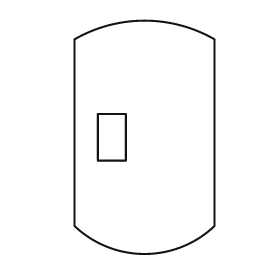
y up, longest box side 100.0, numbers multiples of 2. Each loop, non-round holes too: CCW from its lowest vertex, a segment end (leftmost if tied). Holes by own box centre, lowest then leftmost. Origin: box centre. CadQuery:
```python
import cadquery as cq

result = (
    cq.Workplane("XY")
    .moveTo(-30.0, -38.0)
    .threePointArc((0.0, -50.0), (30.0, -38.0))
    .lineTo(30.0, 42.0)
    .threePointArc((0.0, 50.0), (-30.0, 42.0))
    .close()
    .moveTo(-20.0, -10.0)
    .lineTo(-8.0, -10.0)
    .lineTo(-8.0, 10.0)
    .lineTo(-20.0, 10.0)
    .close()
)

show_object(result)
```